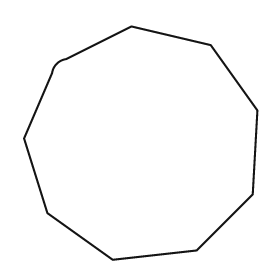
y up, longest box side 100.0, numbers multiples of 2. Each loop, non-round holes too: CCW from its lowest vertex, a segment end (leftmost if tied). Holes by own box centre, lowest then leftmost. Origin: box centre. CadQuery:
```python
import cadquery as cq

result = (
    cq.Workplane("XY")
    .moveTo(-12.0, -50.0)
    .lineTo(24.0, -46.0)
    .lineTo(48.0, -22.0)
    .lineTo(50.0, 14.0)
    .lineTo(30.0, 42.0)
    .lineTo(-4.0, 50.0)
    .lineTo(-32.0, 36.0)
    .threePointArc((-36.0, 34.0), (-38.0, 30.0))
    .lineTo(-50.0, 2.0)
    .lineTo(-40.0, -30.0)
    .close()
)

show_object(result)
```